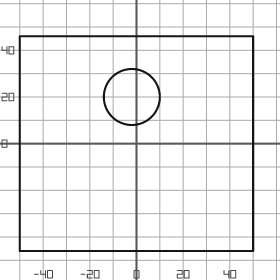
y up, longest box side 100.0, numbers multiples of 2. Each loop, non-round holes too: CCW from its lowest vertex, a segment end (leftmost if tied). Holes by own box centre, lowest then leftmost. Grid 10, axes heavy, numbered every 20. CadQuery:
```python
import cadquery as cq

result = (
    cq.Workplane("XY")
    .moveTo(-50.0, -46.0)
    .lineTo(50.0, -46.0)
    .lineTo(50.0, 46.0)
    .lineTo(-50.0, 46.0)
    .close()
    .moveTo(-2.0, 20.0)
    .circle(12.0)
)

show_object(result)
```